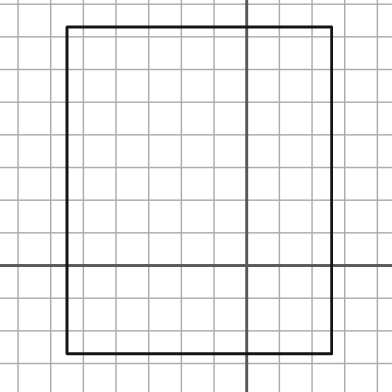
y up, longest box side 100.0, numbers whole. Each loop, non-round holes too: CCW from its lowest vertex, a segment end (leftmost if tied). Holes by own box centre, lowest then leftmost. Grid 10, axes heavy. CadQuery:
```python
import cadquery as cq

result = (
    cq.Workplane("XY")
    .moveTo(-55.0, -27.0)
    .lineTo(26.0, -27.0)
    .lineTo(26.0, 73.0)
    .lineTo(-55.0, 73.0)
    .close()
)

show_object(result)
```